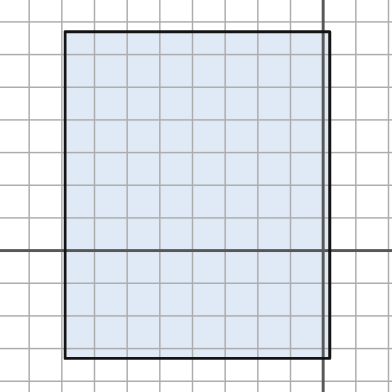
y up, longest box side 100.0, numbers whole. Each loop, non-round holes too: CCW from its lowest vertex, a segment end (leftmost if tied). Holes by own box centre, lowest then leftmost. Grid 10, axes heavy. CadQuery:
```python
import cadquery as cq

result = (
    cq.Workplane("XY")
    .moveTo(-79.0, -33.0)
    .lineTo(2.0, -33.0)
    .lineTo(2.0, 67.0)
    .lineTo(-79.0, 67.0)
    .close()
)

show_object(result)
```